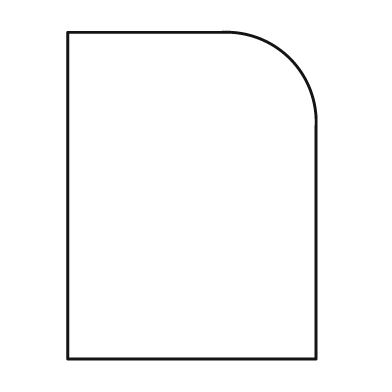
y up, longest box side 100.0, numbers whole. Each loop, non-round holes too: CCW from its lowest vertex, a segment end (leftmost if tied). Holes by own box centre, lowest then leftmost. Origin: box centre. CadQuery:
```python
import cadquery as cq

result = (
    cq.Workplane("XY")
    .moveTo(-38.0, -50.0)
    .lineTo(38.0, -50.0)
    .lineTo(38.0, 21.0)
    .threePointArc((30.0, 42.0), (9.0, 50.0))
    .lineTo(-38.0, 50.0)
    .close()
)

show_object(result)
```